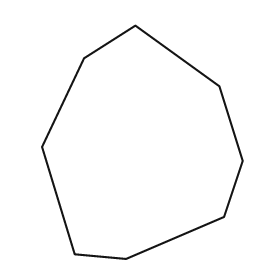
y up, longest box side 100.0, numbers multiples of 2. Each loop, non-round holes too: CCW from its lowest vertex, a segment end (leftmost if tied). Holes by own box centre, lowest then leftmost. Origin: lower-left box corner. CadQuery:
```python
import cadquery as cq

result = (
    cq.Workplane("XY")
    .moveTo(36.0, 0.0)
    .lineTo(78.0, 18.0)
    .lineTo(86.0, 42.0)
    .lineTo(76.0, 74.0)
    .lineTo(40.0, 100.0)
    .lineTo(18.0, 86.0)
    .lineTo(0.0, 48.0)
    .lineTo(14.0, 2.0)
    .close()
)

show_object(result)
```